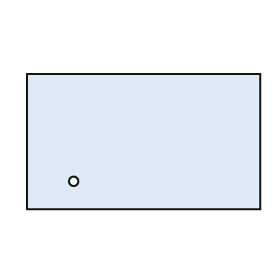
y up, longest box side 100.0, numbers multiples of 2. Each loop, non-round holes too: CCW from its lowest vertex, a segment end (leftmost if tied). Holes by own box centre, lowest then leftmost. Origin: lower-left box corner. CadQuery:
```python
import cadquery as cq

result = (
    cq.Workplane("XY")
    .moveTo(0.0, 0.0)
    .lineTo(100.0, 0.0)
    .lineTo(100.0, 58.0)
    .lineTo(0.0, 58.0)
    .close()
    .moveTo(20.0, 12.0)
    .circle(2.0)
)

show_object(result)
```